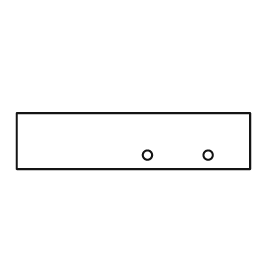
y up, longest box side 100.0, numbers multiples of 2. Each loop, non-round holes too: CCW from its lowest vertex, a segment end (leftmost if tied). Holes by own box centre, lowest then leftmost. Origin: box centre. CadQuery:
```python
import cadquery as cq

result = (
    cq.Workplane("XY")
    .moveTo(-50.0, -12.0)
    .lineTo(50.0, -12.0)
    .lineTo(50.0, 12.0)
    .lineTo(-50.0, 12.0)
    .close()
    .moveTo(6.0, -6.0)
    .circle(2.0)
    .moveTo(32.0, -6.0)
    .circle(2.0)
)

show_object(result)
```